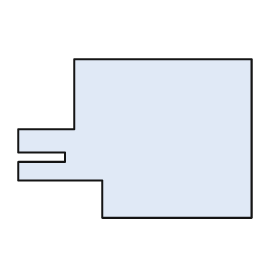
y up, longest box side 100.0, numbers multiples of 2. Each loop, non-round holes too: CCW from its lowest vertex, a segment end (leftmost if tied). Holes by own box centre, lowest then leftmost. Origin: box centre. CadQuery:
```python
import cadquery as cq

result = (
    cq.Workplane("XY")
    .moveTo(-14.0, -34.0)
    .lineTo(50.0, -34.0)
    .lineTo(50.0, 34.0)
    .lineTo(-26.0, 34.0)
    .lineTo(-26.0, 4.0)
    .lineTo(-50.0, 4.0)
    .lineTo(-50.0, -6.0)
    .lineTo(-30.0, -6.0)
    .lineTo(-30.0, -10.0)
    .lineTo(-50.0, -10.0)
    .lineTo(-50.0, -18.0)
    .lineTo(-14.0, -18.0)
    .close()
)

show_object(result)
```